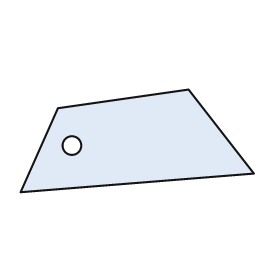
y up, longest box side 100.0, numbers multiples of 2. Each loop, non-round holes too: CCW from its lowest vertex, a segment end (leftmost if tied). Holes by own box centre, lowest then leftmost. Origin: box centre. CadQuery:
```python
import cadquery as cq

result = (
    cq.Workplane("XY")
    .moveTo(-50.0, -22.0)
    .lineTo(50.0, -14.0)
    .lineTo(22.0, 22.0)
    .lineTo(-34.0, 14.0)
    .close()
    .moveTo(-28.0, -2.0)
    .circle(4.0)
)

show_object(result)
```